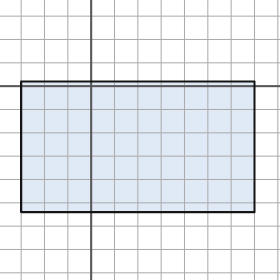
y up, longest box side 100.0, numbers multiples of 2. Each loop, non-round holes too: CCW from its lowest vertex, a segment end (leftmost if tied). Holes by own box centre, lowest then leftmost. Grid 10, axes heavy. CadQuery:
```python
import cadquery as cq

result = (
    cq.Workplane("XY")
    .moveTo(-30.0, -54.0)
    .lineTo(70.0, -54.0)
    .lineTo(70.0, 2.0)
    .lineTo(-30.0, 2.0)
    .close()
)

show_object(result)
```